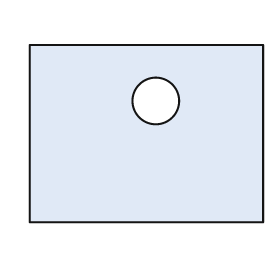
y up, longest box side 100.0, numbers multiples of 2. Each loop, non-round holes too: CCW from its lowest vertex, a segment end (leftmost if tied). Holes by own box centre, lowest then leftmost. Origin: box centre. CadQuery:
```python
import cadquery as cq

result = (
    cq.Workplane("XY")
    .moveTo(-50.0, -38.0)
    .lineTo(50.0, -38.0)
    .lineTo(50.0, 38.0)
    .lineTo(-50.0, 38.0)
    .close()
    .moveTo(4.0, 14.0)
    .circle(10.0)
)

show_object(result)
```